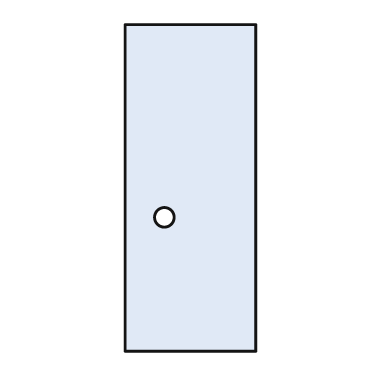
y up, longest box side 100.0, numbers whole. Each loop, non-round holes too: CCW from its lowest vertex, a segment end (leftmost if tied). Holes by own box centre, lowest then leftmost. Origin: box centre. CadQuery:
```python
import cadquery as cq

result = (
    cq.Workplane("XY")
    .moveTo(-20.0, -50.0)
    .lineTo(20.0, -50.0)
    .lineTo(20.0, 50.0)
    .lineTo(-20.0, 50.0)
    .close()
    .moveTo(-8.0, -9.0)
    .circle(3.0)
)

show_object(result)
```